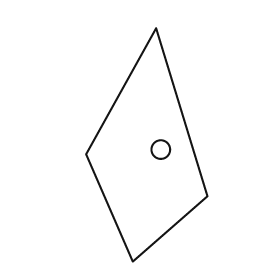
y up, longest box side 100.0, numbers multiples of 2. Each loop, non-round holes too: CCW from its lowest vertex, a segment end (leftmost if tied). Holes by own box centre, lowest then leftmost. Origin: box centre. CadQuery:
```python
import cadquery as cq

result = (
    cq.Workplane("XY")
    .moveTo(-6.0, -50.0)
    .lineTo(26.0, -22.0)
    .lineTo(4.0, 50.0)
    .lineTo(-26.0, -4.0)
    .close()
    .moveTo(6.0, -2.0)
    .circle(4.0)
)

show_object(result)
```